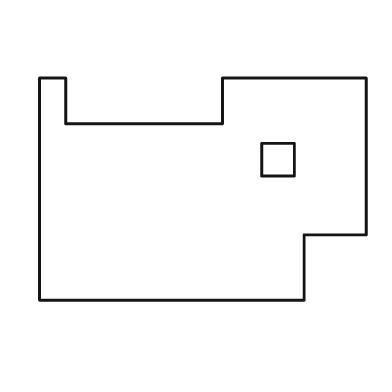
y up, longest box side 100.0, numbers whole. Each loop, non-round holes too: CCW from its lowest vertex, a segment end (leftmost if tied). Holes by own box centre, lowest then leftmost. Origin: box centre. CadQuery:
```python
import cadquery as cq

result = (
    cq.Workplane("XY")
    .moveTo(-50.0, -34.0)
    .lineTo(31.0, -34.0)
    .lineTo(31.0, -14.0)
    .lineTo(50.0, -14.0)
    .lineTo(50.0, 34.0)
    .lineTo(6.0, 34.0)
    .lineTo(6.0, 20.0)
    .lineTo(-42.0, 20.0)
    .lineTo(-42.0, 34.0)
    .lineTo(-50.0, 34.0)
    .close()
    .moveTo(18.0, 4.0)
    .lineTo(28.0, 4.0)
    .lineTo(28.0, 14.0)
    .lineTo(18.0, 14.0)
    .close()
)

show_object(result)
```